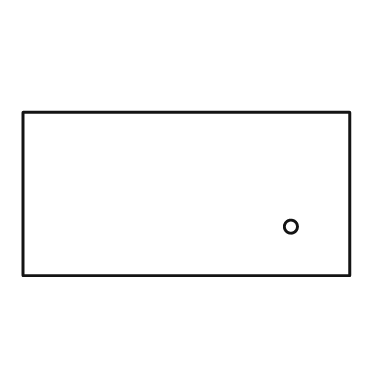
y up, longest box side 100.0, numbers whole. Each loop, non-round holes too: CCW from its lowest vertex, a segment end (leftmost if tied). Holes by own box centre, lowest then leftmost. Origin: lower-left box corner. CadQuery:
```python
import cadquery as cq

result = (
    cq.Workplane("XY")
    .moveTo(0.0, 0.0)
    .lineTo(100.0, 0.0)
    .lineTo(100.0, 50.0)
    .lineTo(0.0, 50.0)
    .close()
    .moveTo(82.0, 15.0)
    .circle(2.0)
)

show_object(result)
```